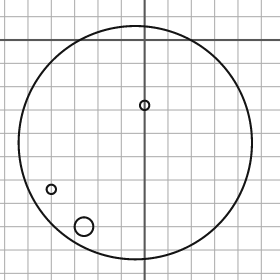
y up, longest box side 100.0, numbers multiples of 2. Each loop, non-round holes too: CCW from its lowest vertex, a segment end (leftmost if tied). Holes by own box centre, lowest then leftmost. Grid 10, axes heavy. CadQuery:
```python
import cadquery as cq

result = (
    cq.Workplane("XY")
    .moveTo(-4.0, -44.0)
    .circle(50.0)
    .moveTo(-26.0, -80.0)
    .circle(4.0)
    .moveTo(-40.0, -64.0)
    .circle(2.0)
    .moveTo(0.0, -28.0)
    .circle(2.0)
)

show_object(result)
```